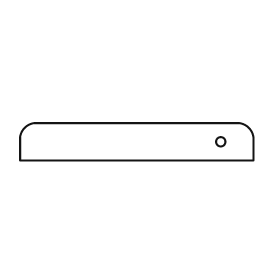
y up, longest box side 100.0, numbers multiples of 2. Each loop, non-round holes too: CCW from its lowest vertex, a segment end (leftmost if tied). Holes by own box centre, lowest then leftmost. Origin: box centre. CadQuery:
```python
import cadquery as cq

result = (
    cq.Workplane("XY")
    .moveTo(-50.0, -8.0)
    .lineTo(50.0, -8.0)
    .lineTo(50.0, 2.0)
    .threePointArc((48.0, 6.0), (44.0, 8.0))
    .lineTo(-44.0, 8.0)
    .threePointArc((-48.0, 6.0), (-50.0, 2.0))
    .close()
    .moveTo(36.0, 0.0)
    .circle(2.0)
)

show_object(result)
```